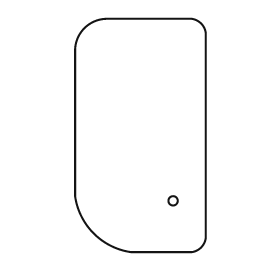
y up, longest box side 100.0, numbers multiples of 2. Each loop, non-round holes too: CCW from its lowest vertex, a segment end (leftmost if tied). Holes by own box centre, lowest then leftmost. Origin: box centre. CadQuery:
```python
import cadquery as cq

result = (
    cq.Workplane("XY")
    .moveTo(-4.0, -50.0)
    .lineTo(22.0, -50.0)
    .threePointArc((26.0, -48.0), (28.0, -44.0))
    .lineTo(28.0, 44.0)
    .threePointArc((26.0, 48.0), (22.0, 50.0))
    .lineTo(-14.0, 50.0)
    .threePointArc((-24.0, 46.0), (-28.0, 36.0))
    .lineTo(-28.0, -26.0)
    .threePointArc((-20.0, -42.0), (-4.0, -50.0))
    .close()
    .moveTo(14.0, -28.0)
    .circle(2.0)
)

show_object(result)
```